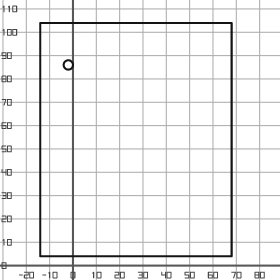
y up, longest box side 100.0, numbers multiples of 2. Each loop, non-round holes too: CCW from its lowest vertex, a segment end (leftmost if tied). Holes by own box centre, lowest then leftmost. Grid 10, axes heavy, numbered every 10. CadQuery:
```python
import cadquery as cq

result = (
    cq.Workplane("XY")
    .moveTo(-14.0, 4.0)
    .lineTo(68.0, 4.0)
    .lineTo(68.0, 104.0)
    .lineTo(-14.0, 104.0)
    .close()
    .moveTo(-2.0, 86.0)
    .circle(2.0)
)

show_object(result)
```